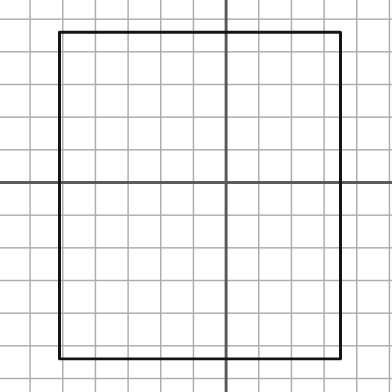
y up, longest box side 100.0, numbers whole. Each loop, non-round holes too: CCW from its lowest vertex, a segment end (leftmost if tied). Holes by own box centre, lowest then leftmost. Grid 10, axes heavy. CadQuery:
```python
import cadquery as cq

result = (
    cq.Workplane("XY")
    .moveTo(-51.0, -54.0)
    .lineTo(35.0, -54.0)
    .lineTo(35.0, 46.0)
    .lineTo(-51.0, 46.0)
    .close()
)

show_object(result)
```